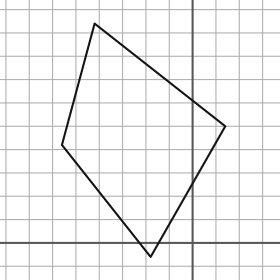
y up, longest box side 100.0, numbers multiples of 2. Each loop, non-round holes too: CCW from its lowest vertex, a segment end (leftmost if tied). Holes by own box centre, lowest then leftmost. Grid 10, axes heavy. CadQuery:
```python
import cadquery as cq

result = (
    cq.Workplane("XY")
    .moveTo(-18.0, -6.0)
    .lineTo(14.0, 50.0)
    .lineTo(-42.0, 94.0)
    .lineTo(-56.0, 42.0)
    .close()
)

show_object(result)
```